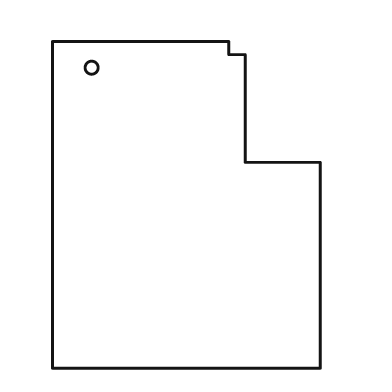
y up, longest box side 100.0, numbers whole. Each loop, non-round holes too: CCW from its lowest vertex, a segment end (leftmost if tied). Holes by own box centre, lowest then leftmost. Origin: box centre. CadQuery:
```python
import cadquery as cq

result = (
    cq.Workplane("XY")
    .moveTo(-41.0, -50.0)
    .lineTo(41.0, -50.0)
    .lineTo(41.0, 13.0)
    .lineTo(18.0, 13.0)
    .lineTo(18.0, 46.0)
    .lineTo(13.0, 46.0)
    .lineTo(13.0, 50.0)
    .lineTo(-41.0, 50.0)
    .close()
    .moveTo(-29.0, 42.0)
    .circle(2.0)
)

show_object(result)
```